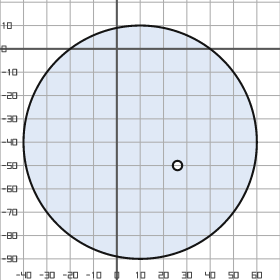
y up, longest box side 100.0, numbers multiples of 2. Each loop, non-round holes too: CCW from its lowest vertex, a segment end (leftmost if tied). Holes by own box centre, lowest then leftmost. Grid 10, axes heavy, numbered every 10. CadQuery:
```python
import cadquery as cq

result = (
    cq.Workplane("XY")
    .moveTo(10.0, -40.0)
    .circle(50.0)
    .moveTo(26.0, -50.0)
    .circle(2.0)
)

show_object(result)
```